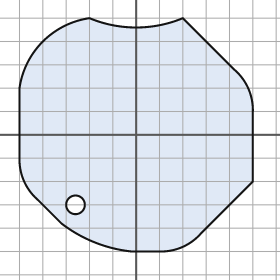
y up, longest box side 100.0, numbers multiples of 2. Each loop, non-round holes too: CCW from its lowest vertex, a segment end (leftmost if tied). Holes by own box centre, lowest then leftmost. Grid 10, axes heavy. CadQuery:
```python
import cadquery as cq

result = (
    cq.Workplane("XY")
    .moveTo(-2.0, -50.0)
    .lineTo(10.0, -50.0)
    .threePointArc((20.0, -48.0), (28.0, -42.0))
    .lineTo(50.0, -20.0)
    .lineTo(50.0, 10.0)
    .threePointArc((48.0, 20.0), (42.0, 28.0))
    .lineTo(20.0, 50.0)
    .threePointArc((0.0, 46.0), (-20.0, 50.0))
    .threePointArc((-40.0, 40.0), (-50.0, 20.0))
    .lineTo(-50.0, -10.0)
    .threePointArc((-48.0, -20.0), (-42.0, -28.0))
    .lineTo(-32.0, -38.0)
    .threePointArc((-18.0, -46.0), (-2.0, -50.0))
    .close()
    .moveTo(-26.0, -30.0)
    .circle(4.0)
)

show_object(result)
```